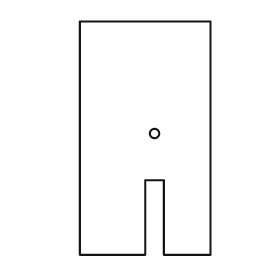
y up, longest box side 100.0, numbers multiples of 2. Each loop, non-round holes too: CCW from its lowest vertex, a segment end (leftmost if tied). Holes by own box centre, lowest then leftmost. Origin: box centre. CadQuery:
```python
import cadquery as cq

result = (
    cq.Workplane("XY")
    .moveTo(-28.0, -50.0)
    .lineTo(0.0, -50.0)
    .lineTo(0.0, -18.0)
    .lineTo(8.0, -18.0)
    .lineTo(8.0, -50.0)
    .lineTo(28.0, -50.0)
    .lineTo(28.0, 50.0)
    .lineTo(-28.0, 50.0)
    .close()
    .moveTo(4.0, 2.0)
    .circle(2.0)
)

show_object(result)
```